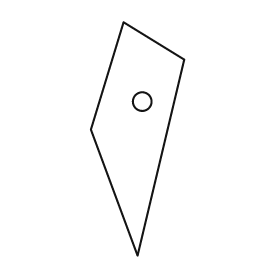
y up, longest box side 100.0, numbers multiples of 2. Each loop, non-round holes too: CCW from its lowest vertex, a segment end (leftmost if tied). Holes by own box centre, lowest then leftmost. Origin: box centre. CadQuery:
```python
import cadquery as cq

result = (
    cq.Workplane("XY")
    .moveTo(0.0, -50.0)
    .lineTo(20.0, 34.0)
    .lineTo(-6.0, 50.0)
    .lineTo(-20.0, 4.0)
    .close()
    .moveTo(2.0, 16.0)
    .circle(4.0)
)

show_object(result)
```